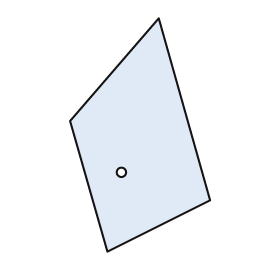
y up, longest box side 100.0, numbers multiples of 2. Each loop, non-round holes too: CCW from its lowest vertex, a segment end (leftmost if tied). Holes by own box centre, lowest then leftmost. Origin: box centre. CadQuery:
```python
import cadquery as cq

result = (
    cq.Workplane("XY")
    .moveTo(-14.0, -50.0)
    .lineTo(30.0, -28.0)
    .lineTo(8.0, 50.0)
    .lineTo(-30.0, 6.0)
    .close()
    .moveTo(-8.0, -16.0)
    .circle(2.0)
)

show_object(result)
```